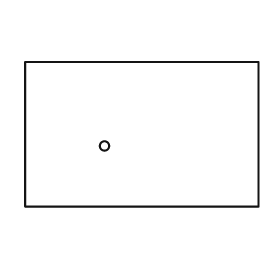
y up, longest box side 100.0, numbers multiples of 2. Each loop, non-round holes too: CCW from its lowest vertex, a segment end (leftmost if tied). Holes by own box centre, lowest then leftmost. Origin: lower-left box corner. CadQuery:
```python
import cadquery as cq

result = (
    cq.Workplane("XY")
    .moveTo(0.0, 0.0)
    .lineTo(100.0, 0.0)
    .lineTo(100.0, 62.0)
    .lineTo(0.0, 62.0)
    .close()
    .moveTo(34.0, 26.0)
    .circle(2.0)
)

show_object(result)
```